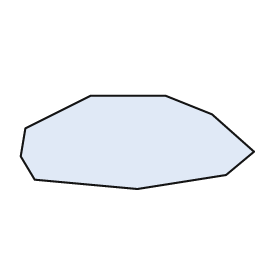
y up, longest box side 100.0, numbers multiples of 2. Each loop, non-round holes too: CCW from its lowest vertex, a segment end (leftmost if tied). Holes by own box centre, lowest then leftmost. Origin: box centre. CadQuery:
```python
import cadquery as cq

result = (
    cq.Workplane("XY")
    .moveTo(0.0, -20.0)
    .lineTo(38.0, -14.0)
    .lineTo(50.0, -4.0)
    .lineTo(32.0, 12.0)
    .lineTo(12.0, 20.0)
    .lineTo(-20.0, 20.0)
    .lineTo(-48.0, 6.0)
    .lineTo(-50.0, -6.0)
    .lineTo(-44.0, -16.0)
    .close()
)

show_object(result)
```